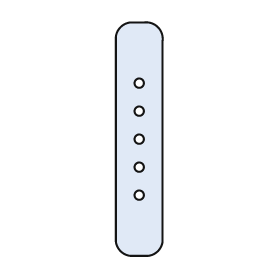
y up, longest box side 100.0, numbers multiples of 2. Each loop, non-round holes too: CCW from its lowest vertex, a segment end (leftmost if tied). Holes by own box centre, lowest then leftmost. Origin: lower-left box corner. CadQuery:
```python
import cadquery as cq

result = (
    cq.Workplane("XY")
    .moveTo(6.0, 0.0)
    .lineTo(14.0, 0.0)
    .threePointArc((18.0, 2.0), (20.0, 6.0))
    .lineTo(20.0, 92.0)
    .threePointArc((18.0, 98.0), (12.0, 100.0))
    .lineTo(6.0, 100.0)
    .threePointArc((2.0, 98.0), (0.0, 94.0))
    .lineTo(0.0, 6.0)
    .threePointArc((2.0, 2.0), (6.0, 0.0))
    .close()
    .moveTo(10.0, 26.0)
    .circle(2.0)
    .moveTo(10.0, 38.0)
    .circle(2.0)
    .moveTo(10.0, 50.0)
    .circle(2.0)
    .moveTo(10.0, 62.0)
    .circle(2.0)
    .moveTo(10.0, 74.0)
    .circle(2.0)
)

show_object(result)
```